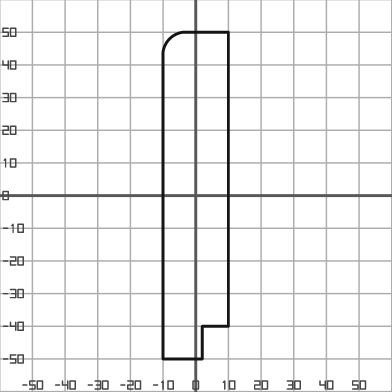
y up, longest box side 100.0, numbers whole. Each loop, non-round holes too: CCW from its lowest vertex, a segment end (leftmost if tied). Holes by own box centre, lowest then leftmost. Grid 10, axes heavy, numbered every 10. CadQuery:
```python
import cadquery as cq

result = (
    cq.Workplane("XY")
    .moveTo(-10.0, -50.0)
    .lineTo(2.0, -50.0)
    .lineTo(2.0, -40.0)
    .lineTo(10.0, -40.0)
    .lineTo(10.0, 50.0)
    .lineTo(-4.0, 50.0)
    .threePointArc((-8.0, 48.0), (-10.0, 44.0))
    .close()
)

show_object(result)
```